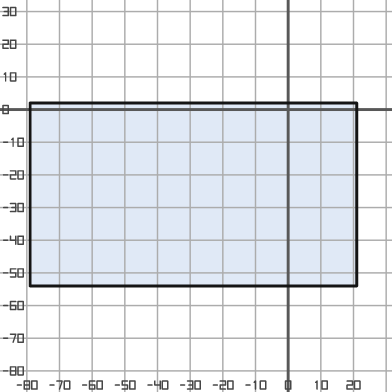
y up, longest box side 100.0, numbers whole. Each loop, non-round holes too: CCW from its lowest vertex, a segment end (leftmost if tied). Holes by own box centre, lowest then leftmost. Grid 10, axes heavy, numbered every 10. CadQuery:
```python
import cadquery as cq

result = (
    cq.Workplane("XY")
    .moveTo(-79.0, -54.0)
    .lineTo(21.0, -54.0)
    .lineTo(21.0, 2.0)
    .lineTo(-79.0, 2.0)
    .close()
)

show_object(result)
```